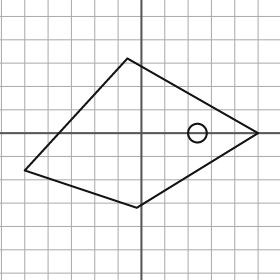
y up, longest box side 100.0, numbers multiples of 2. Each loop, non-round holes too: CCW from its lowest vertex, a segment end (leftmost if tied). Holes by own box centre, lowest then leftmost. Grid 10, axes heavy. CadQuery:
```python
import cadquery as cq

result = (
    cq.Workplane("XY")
    .moveTo(-2.0, -32.0)
    .lineTo(50.0, 0.0)
    .lineTo(-6.0, 32.0)
    .lineTo(-50.0, -16.0)
    .close()
    .moveTo(24.0, 0.0)
    .circle(4.0)
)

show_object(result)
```